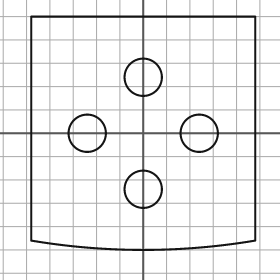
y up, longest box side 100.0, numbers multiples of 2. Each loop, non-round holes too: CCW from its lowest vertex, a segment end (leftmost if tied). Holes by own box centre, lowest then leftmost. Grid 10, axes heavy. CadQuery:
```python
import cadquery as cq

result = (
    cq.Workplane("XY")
    .moveTo(-48.0, -46.0)
    .threePointArc((0.0, -50.0), (48.0, -46.0))
    .lineTo(48.0, 50.0)
    .lineTo(-48.0, 50.0)
    .close()
    .moveTo(0.0, -24.0)
    .circle(8.0)
    .moveTo(-24.0, 0.0)
    .circle(8.0)
    .moveTo(24.0, 0.0)
    .circle(8.0)
    .moveTo(0.0, 24.0)
    .circle(8.0)
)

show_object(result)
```